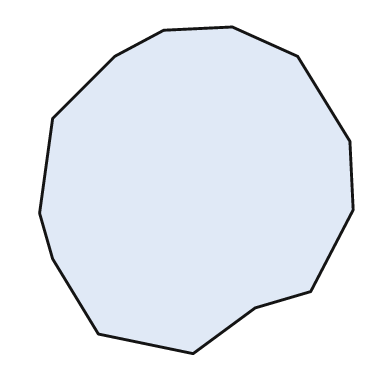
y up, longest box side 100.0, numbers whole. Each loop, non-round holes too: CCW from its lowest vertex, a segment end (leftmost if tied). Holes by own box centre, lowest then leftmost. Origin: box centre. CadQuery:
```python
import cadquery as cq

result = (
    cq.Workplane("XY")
    .moveTo(-1.0, -50.0)
    .lineTo(18.0, -36.0)
    .lineTo(35.0, -31.0)
    .lineTo(48.0, -6.0)
    .lineTo(47.0, 15.0)
    .lineTo(31.0, 41.0)
    .lineTo(11.0, 50.0)
    .lineTo(-10.0, 49.0)
    .lineTo(-25.0, 41.0)
    .lineTo(-44.0, 22.0)
    .lineTo(-48.0, -7.0)
    .lineTo(-44.0, -21.0)
    .lineTo(-30.0, -44.0)
    .close()
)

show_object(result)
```